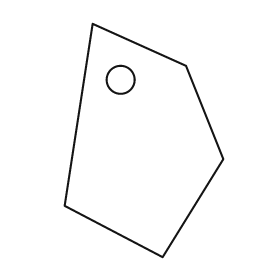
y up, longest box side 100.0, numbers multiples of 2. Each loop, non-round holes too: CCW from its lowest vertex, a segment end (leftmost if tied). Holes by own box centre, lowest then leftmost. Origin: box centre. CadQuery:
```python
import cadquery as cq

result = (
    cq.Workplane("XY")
    .moveTo(8.0, -50.0)
    .lineTo(34.0, -8.0)
    .lineTo(18.0, 32.0)
    .lineTo(-22.0, 50.0)
    .lineTo(-34.0, -28.0)
    .close()
    .moveTo(-10.0, 26.0)
    .circle(6.0)
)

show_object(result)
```